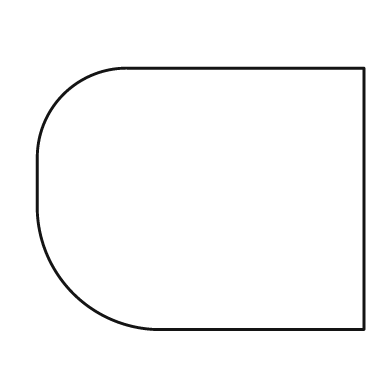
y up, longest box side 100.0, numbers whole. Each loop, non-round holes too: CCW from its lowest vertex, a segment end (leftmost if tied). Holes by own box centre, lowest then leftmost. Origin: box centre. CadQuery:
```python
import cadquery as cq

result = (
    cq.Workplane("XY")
    .moveTo(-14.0, -40.0)
    .lineTo(50.0, -40.0)
    .lineTo(50.0, 40.0)
    .lineTo(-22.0, 40.0)
    .threePointArc((-42.0, 32.0), (-50.0, 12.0))
    .lineTo(-50.0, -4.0)
    .threePointArc((-39.0, -29.0), (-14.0, -40.0))
    .close()
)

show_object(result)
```